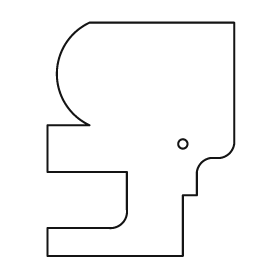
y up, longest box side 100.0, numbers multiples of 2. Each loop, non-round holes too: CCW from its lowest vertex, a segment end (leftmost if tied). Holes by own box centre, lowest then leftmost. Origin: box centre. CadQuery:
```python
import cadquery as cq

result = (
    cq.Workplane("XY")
    .moveTo(-40.0, -50.0)
    .lineTo(18.0, -50.0)
    .lineTo(18.0, -24.0)
    .lineTo(24.0, -24.0)
    .lineTo(24.0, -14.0)
    .threePointArc((26.0, -10.0), (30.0, -8.0))
    .lineTo(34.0, -8.0)
    .threePointArc((38.0, -6.0), (40.0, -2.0))
    .lineTo(40.0, 50.0)
    .lineTo(-22.0, 50.0)
    .threePointArc((-36.0, 28.0), (-22.0, 6.0))
    .lineTo(-40.0, 6.0)
    .lineTo(-40.0, -14.0)
    .lineTo(-6.0, -14.0)
    .lineTo(-6.0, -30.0)
    .threePointArc((-8.0, -36.0), (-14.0, -38.0))
    .lineTo(-40.0, -38.0)
    .close()
    .moveTo(18.0, -2.0)
    .circle(2.0)
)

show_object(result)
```